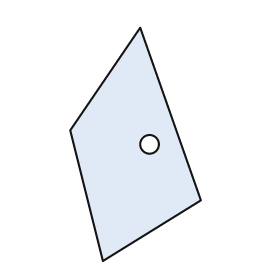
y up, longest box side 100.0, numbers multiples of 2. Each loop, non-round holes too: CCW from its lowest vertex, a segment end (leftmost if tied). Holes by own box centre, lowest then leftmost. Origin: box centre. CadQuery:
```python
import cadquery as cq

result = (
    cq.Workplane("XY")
    .moveTo(-14.0, -50.0)
    .lineTo(28.0, -24.0)
    .lineTo(2.0, 50.0)
    .lineTo(-28.0, 6.0)
    .close()
    .moveTo(6.0, 0.0)
    .circle(4.0)
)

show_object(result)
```